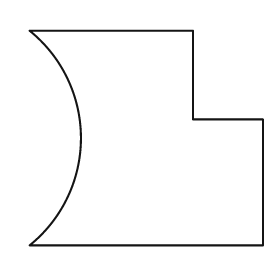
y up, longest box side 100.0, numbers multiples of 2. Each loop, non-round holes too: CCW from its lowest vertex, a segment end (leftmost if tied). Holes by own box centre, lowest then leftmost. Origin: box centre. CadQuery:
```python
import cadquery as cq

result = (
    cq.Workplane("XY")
    .moveTo(-50.0, -46.0)
    .lineTo(50.0, -46.0)
    .lineTo(50.0, 8.0)
    .lineTo(20.0, 8.0)
    .lineTo(20.0, 46.0)
    .lineTo(-50.0, 46.0)
    .threePointArc((-28.0, 0.0), (-50.0, -46.0))
    .close()
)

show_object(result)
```